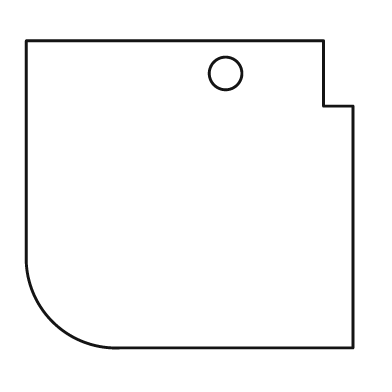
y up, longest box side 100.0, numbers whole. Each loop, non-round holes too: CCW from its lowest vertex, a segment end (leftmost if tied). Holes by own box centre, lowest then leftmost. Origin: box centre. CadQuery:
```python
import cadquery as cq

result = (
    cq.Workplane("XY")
    .moveTo(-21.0, -47.0)
    .lineTo(50.0, -47.0)
    .lineTo(50.0, 27.0)
    .lineTo(41.0, 27.0)
    .lineTo(41.0, 47.0)
    .lineTo(-50.0, 47.0)
    .lineTo(-50.0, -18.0)
    .threePointArc((-42.0, -39.0), (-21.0, -47.0))
    .close()
    .moveTo(11.0, 37.0)
    .circle(5.0)
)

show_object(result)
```